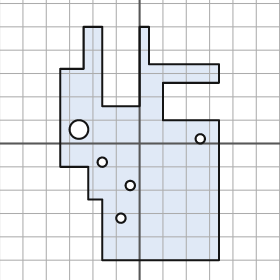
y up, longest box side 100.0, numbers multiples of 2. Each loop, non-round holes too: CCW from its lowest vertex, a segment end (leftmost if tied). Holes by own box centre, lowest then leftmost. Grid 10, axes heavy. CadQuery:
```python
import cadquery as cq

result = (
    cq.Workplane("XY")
    .moveTo(-16.0, -50.0)
    .lineTo(34.0, -50.0)
    .lineTo(34.0, 10.0)
    .lineTo(10.0, 10.0)
    .lineTo(10.0, 26.0)
    .lineTo(34.0, 26.0)
    .lineTo(34.0, 34.0)
    .lineTo(4.0, 34.0)
    .lineTo(4.0, 50.0)
    .lineTo(0.0, 50.0)
    .lineTo(0.0, 16.0)
    .lineTo(-16.0, 16.0)
    .lineTo(-16.0, 50.0)
    .lineTo(-24.0, 50.0)
    .lineTo(-24.0, 32.0)
    .lineTo(-34.0, 32.0)
    .lineTo(-34.0, -10.0)
    .lineTo(-22.0, -10.0)
    .lineTo(-22.0, -24.0)
    .lineTo(-16.0, -24.0)
    .close()
    .moveTo(-8.0, -32.0)
    .circle(2.0)
    .moveTo(-4.0, -18.0)
    .circle(2.0)
    .moveTo(-16.0, -8.0)
    .circle(2.0)
    .moveTo(26.0, 2.0)
    .circle(2.0)
    .moveTo(-26.0, 6.0)
    .circle(4.0)
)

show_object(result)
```